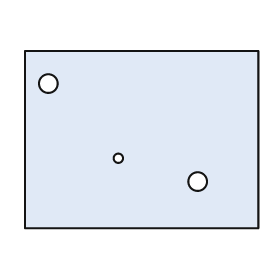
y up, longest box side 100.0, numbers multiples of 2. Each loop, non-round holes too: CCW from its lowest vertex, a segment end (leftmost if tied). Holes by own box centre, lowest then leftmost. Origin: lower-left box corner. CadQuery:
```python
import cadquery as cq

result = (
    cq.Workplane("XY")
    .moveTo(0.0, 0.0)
    .lineTo(100.0, 0.0)
    .lineTo(100.0, 76.0)
    .lineTo(0.0, 76.0)
    .close()
    .moveTo(74.0, 20.0)
    .circle(4.0)
    .moveTo(40.0, 30.0)
    .circle(2.0)
    .moveTo(10.0, 62.0)
    .circle(4.0)
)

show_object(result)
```